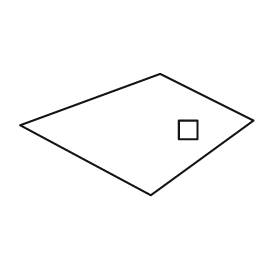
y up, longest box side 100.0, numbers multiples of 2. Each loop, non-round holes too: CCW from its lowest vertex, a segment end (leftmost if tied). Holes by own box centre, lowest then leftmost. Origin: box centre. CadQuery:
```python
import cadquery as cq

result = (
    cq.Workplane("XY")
    .moveTo(6.0, -26.0)
    .lineTo(50.0, 6.0)
    .lineTo(10.0, 26.0)
    .lineTo(-50.0, 4.0)
    .close()
    .moveTo(18.0, -2.0)
    .lineTo(26.0, -2.0)
    .lineTo(26.0, 6.0)
    .lineTo(18.0, 6.0)
    .close()
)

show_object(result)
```